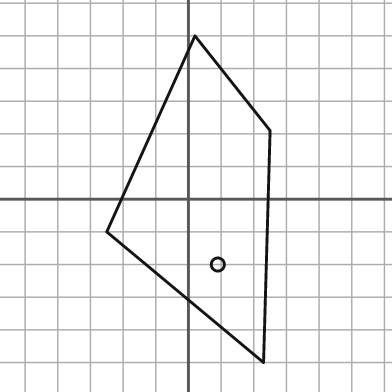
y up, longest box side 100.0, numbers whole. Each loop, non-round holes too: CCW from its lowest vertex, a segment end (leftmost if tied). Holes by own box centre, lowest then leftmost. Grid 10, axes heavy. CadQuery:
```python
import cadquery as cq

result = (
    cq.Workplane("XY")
    .moveTo(23.0, -50.0)
    .lineTo(25.0, 21.0)
    .lineTo(2.0, 50.0)
    .lineTo(-25.0, -10.0)
    .close()
    .moveTo(9.0, -20.0)
    .circle(2.0)
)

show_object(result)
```